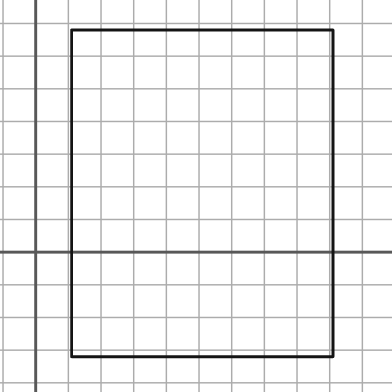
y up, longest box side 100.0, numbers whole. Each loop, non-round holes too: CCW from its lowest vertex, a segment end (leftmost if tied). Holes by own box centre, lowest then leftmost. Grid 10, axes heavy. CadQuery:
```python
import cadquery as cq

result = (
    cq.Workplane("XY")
    .moveTo(11.0, -32.0)
    .lineTo(91.0, -32.0)
    .lineTo(91.0, 68.0)
    .lineTo(11.0, 68.0)
    .close()
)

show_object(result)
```